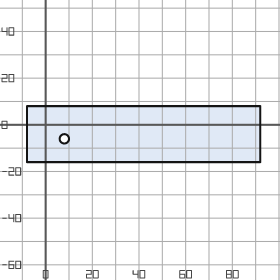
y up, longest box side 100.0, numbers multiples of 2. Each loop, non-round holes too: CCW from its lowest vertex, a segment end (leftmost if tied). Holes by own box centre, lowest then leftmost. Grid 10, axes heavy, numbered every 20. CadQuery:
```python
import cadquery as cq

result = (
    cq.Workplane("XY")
    .moveTo(-8.0, -16.0)
    .lineTo(92.0, -16.0)
    .lineTo(92.0, 8.0)
    .lineTo(-8.0, 8.0)
    .close()
    .moveTo(8.0, -6.0)
    .circle(2.0)
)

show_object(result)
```